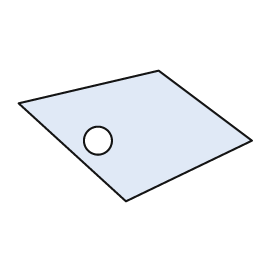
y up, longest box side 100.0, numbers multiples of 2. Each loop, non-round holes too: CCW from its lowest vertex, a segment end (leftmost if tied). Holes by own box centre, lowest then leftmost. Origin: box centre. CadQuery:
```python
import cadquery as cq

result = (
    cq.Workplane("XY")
    .moveTo(-4.0, -28.0)
    .lineTo(50.0, -2.0)
    .lineTo(10.0, 28.0)
    .lineTo(-50.0, 14.0)
    .close()
    .moveTo(-16.0, -2.0)
    .circle(6.0)
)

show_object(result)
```